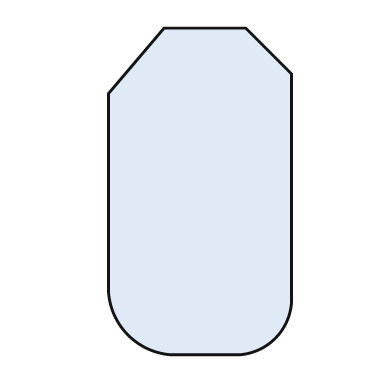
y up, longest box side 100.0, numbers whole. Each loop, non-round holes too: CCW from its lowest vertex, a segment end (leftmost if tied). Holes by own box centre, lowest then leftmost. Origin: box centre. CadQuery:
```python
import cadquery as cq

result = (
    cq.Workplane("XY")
    .moveTo(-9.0, -50.0)
    .lineTo(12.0, -50.0)
    .threePointArc((23.0, -45.0), (28.0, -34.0))
    .lineTo(28.0, 36.0)
    .lineTo(14.0, 50.0)
    .lineTo(-11.0, 50.0)
    .lineTo(-28.0, 30.0)
    .lineTo(-28.0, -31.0)
    .threePointArc((-22.0, -44.0), (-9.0, -50.0))
    .close()
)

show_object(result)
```